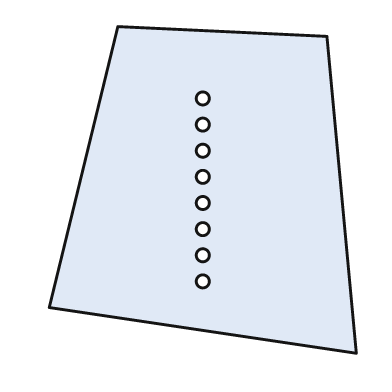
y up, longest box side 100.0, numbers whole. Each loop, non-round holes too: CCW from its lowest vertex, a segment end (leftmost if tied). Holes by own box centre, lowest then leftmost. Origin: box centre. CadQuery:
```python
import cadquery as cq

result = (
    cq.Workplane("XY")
    .moveTo(47.0, -50.0)
    .lineTo(38.0, 47.0)
    .lineTo(-26.0, 50.0)
    .lineTo(-47.0, -36.0)
    .close()
    .moveTo(0.0, -28.0)
    .circle(2.0)
    .moveTo(0.0, -20.0)
    .circle(2.0)
    .moveTo(0.0, -12.0)
    .circle(2.0)
    .moveTo(0.0, -4.0)
    .circle(2.0)
    .moveTo(0.0, 4.0)
    .circle(2.0)
    .moveTo(0.0, 12.0)
    .circle(2.0)
    .moveTo(0.0, 20.0)
    .circle(2.0)
    .moveTo(0.0, 28.0)
    .circle(2.0)
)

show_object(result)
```